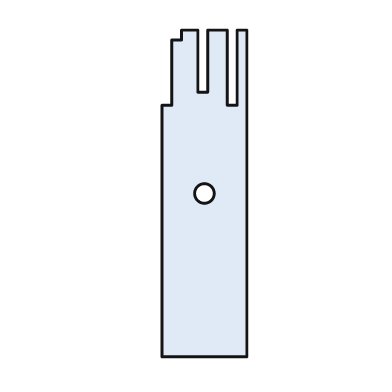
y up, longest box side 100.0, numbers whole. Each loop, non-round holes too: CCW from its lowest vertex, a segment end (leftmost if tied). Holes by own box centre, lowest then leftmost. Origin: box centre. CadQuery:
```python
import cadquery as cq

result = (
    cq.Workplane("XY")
    .moveTo(-13.0, -50.0)
    .lineTo(13.0, -50.0)
    .lineTo(13.0, 50.0)
    .lineTo(10.0, 50.0)
    .lineTo(10.0, 27.0)
    .lineTo(7.0, 27.0)
    .lineTo(7.0, 50.0)
    .lineTo(1.0, 50.0)
    .lineTo(1.0, 31.0)
    .lineTo(-2.0, 31.0)
    .lineTo(-2.0, 50.0)
    .lineTo(-7.0, 50.0)
    .lineTo(-7.0, 47.0)
    .lineTo(-10.0, 47.0)
    .lineTo(-10.0, 27.0)
    .lineTo(-13.0, 27.0)
    .close()
    .moveTo(0.0, 0.0)
    .circle(3.0)
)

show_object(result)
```